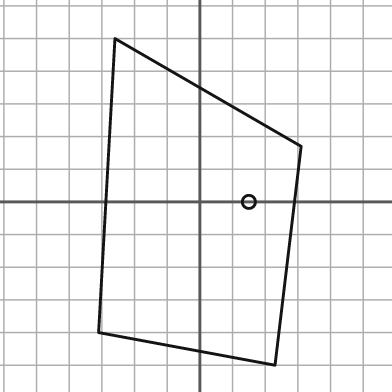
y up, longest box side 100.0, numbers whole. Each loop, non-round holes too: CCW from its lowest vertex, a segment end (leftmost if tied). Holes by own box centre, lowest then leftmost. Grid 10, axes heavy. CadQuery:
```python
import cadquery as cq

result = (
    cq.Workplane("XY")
    .moveTo(23.0, -50.0)
    .lineTo(31.0, 17.0)
    .lineTo(-26.0, 50.0)
    .lineTo(-31.0, -40.0)
    .close()
    .moveTo(15.0, 0.0)
    .circle(2.0)
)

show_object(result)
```